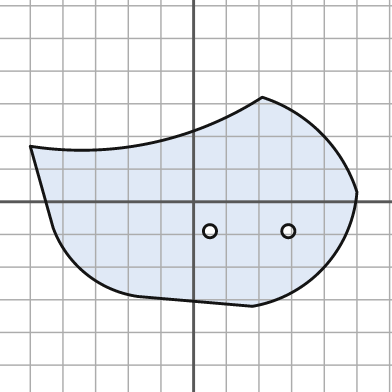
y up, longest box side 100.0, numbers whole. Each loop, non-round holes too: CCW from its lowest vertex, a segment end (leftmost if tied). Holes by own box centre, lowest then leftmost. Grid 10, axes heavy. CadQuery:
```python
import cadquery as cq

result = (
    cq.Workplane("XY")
    .moveTo(18.0, -32.0)
    .threePointArc((40.0, -20.0), (50.0, 3.0))
    .threePointArc((39.0, 21.0), (21.0, 32.0))
    .threePointArc((-13.0, 18.0), (-50.0, 17.0))
    .lineTo(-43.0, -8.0)
    .threePointArc((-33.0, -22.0), (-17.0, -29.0))
    .close()
    .moveTo(5.0, -9.0)
    .circle(2.0)
    .moveTo(29.0, -9.0)
    .circle(2.0)
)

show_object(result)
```